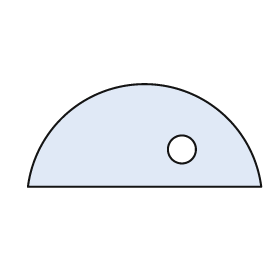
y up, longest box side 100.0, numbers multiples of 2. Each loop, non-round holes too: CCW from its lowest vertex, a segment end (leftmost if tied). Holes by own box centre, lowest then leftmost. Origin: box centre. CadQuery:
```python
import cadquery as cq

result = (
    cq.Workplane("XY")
    .moveTo(-50.0, -22.0)
    .lineTo(50.0, -22.0)
    .threePointArc((0.0, 22.0), (-50.0, -22.0))
    .close()
    .moveTo(16.0, -6.0)
    .circle(6.0)
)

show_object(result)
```